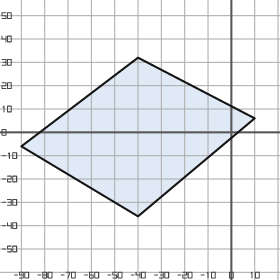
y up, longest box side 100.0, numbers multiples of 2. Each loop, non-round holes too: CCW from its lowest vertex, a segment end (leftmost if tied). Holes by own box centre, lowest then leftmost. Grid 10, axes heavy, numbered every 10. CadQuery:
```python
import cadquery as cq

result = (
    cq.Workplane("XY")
    .moveTo(-40.0, -36.0)
    .lineTo(10.0, 6.0)
    .lineTo(-40.0, 32.0)
    .lineTo(-90.0, -6.0)
    .close()
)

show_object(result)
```